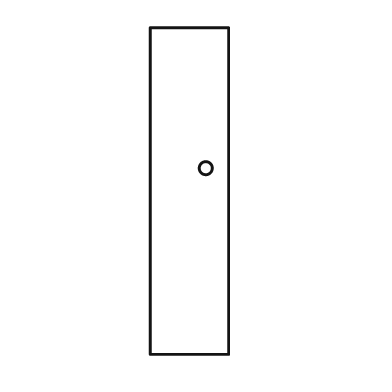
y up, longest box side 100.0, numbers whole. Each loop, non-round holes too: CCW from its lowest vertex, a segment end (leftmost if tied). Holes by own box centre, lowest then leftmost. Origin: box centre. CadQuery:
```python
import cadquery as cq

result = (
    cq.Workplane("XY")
    .moveTo(-12.0, -50.0)
    .lineTo(12.0, -50.0)
    .lineTo(12.0, 50.0)
    .lineTo(-12.0, 50.0)
    .close()
    .moveTo(5.0, 7.0)
    .circle(2.0)
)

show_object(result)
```